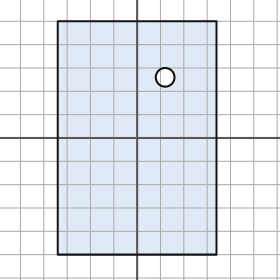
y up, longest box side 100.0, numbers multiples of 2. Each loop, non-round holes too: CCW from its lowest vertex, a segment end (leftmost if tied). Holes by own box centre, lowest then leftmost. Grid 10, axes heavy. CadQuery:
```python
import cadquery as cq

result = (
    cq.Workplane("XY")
    .moveTo(-34.0, -50.0)
    .lineTo(34.0, -50.0)
    .lineTo(34.0, 50.0)
    .lineTo(-34.0, 50.0)
    .close()
    .moveTo(12.0, 26.0)
    .circle(4.0)
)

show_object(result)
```